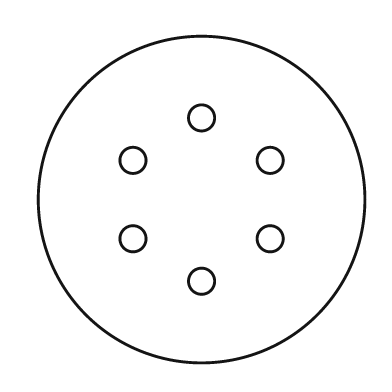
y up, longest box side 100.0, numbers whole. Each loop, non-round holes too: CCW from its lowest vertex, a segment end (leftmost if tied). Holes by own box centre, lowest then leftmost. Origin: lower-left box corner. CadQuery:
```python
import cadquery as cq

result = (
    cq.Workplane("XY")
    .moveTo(50.0, 50.0)
    .circle(50.0)
    .moveTo(50.0, 25.0)
    .circle(4.0)
    .moveTo(29.0, 38.0)
    .circle(4.0)
    .moveTo(71.0, 38.0)
    .circle(4.0)
    .moveTo(29.0, 62.0)
    .circle(4.0)
    .moveTo(71.0, 62.0)
    .circle(4.0)
    .moveTo(50.0, 75.0)
    .circle(4.0)
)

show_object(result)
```